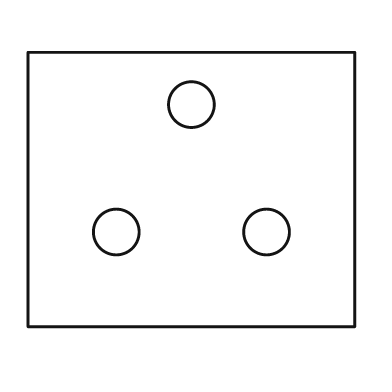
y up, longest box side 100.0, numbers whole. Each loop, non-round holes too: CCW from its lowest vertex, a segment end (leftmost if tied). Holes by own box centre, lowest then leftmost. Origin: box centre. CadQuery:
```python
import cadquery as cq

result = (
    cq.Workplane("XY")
    .moveTo(-50.0, -42.0)
    .lineTo(50.0, -42.0)
    .lineTo(50.0, 42.0)
    .lineTo(-50.0, 42.0)
    .close()
    .moveTo(-23.0, -13.0)
    .circle(7.0)
    .moveTo(23.0, -13.0)
    .circle(7.0)
    .moveTo(0.0, 26.0)
    .circle(7.0)
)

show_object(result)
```